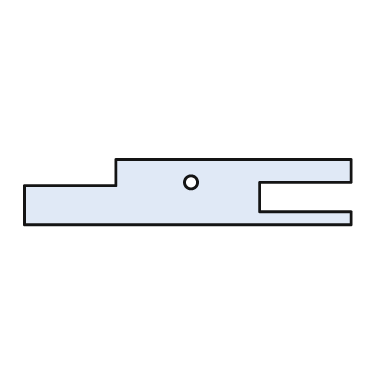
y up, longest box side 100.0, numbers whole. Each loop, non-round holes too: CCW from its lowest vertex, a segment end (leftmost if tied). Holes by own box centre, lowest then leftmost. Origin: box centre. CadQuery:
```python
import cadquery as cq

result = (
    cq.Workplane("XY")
    .moveTo(-50.0, -10.0)
    .lineTo(50.0, -10.0)
    .lineTo(50.0, -6.0)
    .lineTo(22.0, -6.0)
    .lineTo(22.0, 3.0)
    .lineTo(50.0, 3.0)
    .lineTo(50.0, 10.0)
    .lineTo(-22.0, 10.0)
    .lineTo(-22.0, 2.0)
    .lineTo(-50.0, 2.0)
    .close()
    .moveTo(1.0, 3.0)
    .circle(2.0)
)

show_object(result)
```